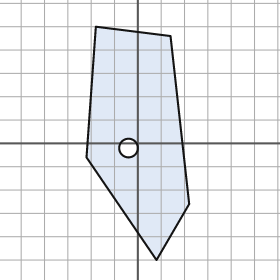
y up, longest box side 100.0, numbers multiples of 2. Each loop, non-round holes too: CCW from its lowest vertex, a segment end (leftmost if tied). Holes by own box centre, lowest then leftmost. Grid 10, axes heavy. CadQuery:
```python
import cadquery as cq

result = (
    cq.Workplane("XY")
    .moveTo(8.0, -50.0)
    .lineTo(22.0, -26.0)
    .lineTo(14.0, 46.0)
    .lineTo(-18.0, 50.0)
    .lineTo(-22.0, -6.0)
    .close()
    .moveTo(-4.0, -2.0)
    .circle(4.0)
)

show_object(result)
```